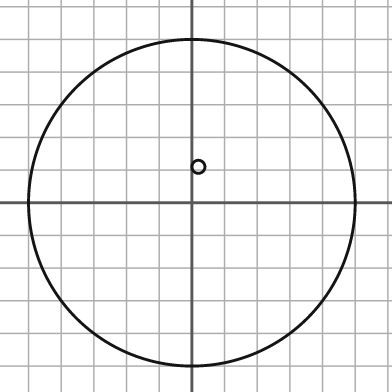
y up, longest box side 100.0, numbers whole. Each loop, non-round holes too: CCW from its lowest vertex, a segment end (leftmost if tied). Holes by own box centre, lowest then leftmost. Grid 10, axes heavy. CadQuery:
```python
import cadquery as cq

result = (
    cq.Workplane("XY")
    .moveTo(0.0, 0.0)
    .circle(50.0)
    .moveTo(2.0, 11.0)
    .circle(2.0)
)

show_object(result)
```